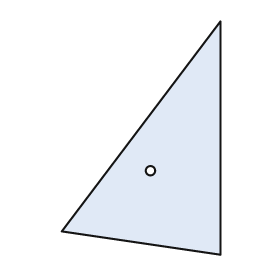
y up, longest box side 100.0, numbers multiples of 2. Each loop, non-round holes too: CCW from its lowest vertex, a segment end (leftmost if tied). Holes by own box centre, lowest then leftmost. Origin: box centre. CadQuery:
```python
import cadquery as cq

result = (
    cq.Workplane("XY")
    .moveTo(34.0, -50.0)
    .lineTo(34.0, 50.0)
    .lineTo(-34.0, -40.0)
    .close()
    .moveTo(4.0, -14.0)
    .circle(2.0)
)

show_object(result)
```